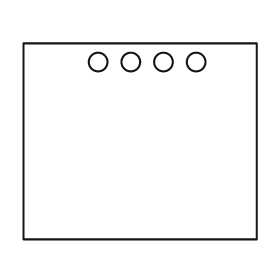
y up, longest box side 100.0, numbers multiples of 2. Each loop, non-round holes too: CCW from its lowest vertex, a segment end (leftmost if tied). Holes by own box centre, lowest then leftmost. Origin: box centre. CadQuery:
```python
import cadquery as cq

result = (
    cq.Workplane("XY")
    .moveTo(-50.0, -42.0)
    .lineTo(50.0, -42.0)
    .lineTo(50.0, 42.0)
    .lineTo(-50.0, 42.0)
    .close()
    .moveTo(-18.0, 34.0)
    .circle(4.0)
    .moveTo(-4.0, 34.0)
    .circle(4.0)
    .moveTo(10.0, 34.0)
    .circle(4.0)
    .moveTo(24.0, 34.0)
    .circle(4.0)
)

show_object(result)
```